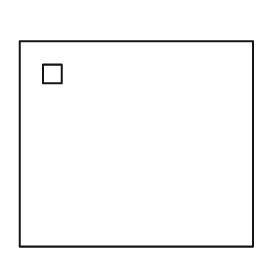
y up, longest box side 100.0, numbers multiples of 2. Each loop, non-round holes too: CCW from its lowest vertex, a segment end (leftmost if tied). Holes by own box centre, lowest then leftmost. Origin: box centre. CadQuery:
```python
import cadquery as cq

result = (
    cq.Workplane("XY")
    .moveTo(-50.0, -44.0)
    .lineTo(50.0, -44.0)
    .lineTo(50.0, 44.0)
    .lineTo(-50.0, 44.0)
    .close()
    .moveTo(-40.0, 26.0)
    .lineTo(-32.0, 26.0)
    .lineTo(-32.0, 34.0)
    .lineTo(-40.0, 34.0)
    .close()
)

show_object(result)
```